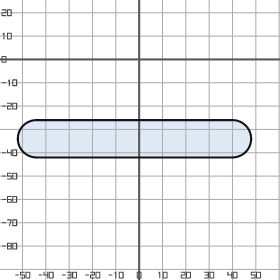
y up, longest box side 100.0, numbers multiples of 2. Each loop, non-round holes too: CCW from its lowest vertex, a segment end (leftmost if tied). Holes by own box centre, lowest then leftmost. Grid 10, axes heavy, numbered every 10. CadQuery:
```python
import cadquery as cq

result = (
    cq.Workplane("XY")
    .moveTo(-44.0, -42.0)
    .lineTo(40.0, -42.0)
    .threePointArc((48.0, -34.0), (40.0, -26.0))
    .lineTo(-44.0, -26.0)
    .threePointArc((-52.0, -34.0), (-44.0, -42.0))
    .close()
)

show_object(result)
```